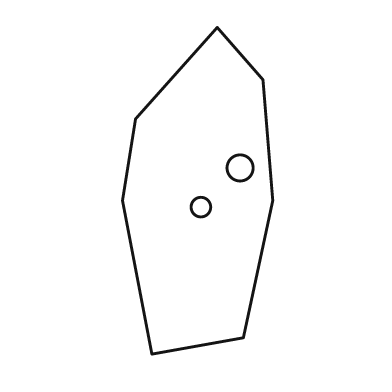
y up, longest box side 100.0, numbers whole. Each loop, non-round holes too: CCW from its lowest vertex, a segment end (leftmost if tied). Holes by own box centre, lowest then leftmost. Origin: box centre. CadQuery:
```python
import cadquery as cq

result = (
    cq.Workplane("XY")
    .moveTo(-14.0, -50.0)
    .lineTo(14.0, -45.0)
    .lineTo(23.0, -3.0)
    .lineTo(20.0, 34.0)
    .lineTo(6.0, 50.0)
    .lineTo(-19.0, 22.0)
    .lineTo(-23.0, -3.0)
    .close()
    .moveTo(1.0, -5.0)
    .circle(3.0)
    .moveTo(13.0, 7.0)
    .circle(4.0)
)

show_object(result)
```